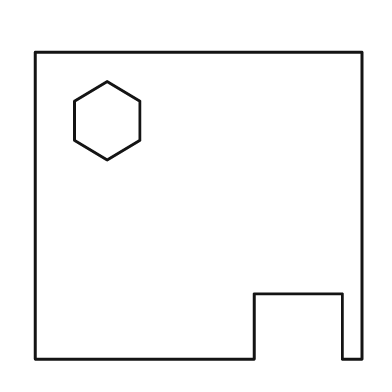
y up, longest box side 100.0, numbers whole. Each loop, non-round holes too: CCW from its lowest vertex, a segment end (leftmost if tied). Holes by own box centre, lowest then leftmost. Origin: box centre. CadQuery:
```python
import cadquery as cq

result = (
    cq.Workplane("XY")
    .moveTo(-50.0, -47.0)
    .lineTo(17.0, -47.0)
    .lineTo(17.0, -27.0)
    .lineTo(44.0, -27.0)
    .lineTo(44.0, -47.0)
    .lineTo(50.0, -47.0)
    .lineTo(50.0, 47.0)
    .lineTo(-50.0, 47.0)
    .close()
    .moveTo(-28.0, 14.0)
    .lineTo(-18.0, 20.0)
    .lineTo(-18.0, 32.0)
    .lineTo(-28.0, 38.0)
    .lineTo(-38.0, 32.0)
    .lineTo(-38.0, 20.0)
    .close()
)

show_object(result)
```